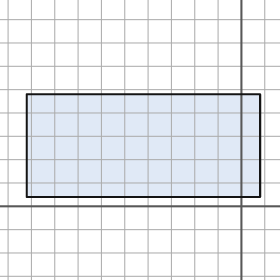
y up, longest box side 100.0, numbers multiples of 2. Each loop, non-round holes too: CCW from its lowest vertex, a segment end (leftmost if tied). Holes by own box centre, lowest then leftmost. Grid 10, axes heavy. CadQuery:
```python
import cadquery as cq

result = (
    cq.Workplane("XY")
    .moveTo(-92.0, 4.0)
    .lineTo(8.0, 4.0)
    .lineTo(8.0, 48.0)
    .lineTo(-92.0, 48.0)
    .close()
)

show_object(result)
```